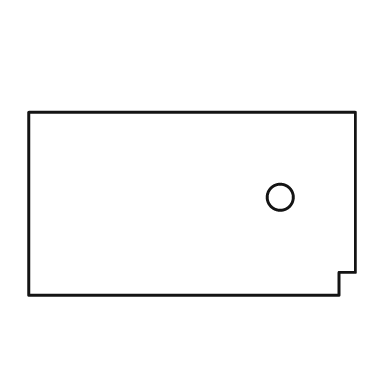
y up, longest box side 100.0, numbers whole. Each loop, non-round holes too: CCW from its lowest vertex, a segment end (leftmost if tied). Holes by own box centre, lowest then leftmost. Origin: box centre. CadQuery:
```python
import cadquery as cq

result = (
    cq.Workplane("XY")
    .moveTo(-50.0, -28.0)
    .lineTo(45.0, -28.0)
    .lineTo(45.0, -21.0)
    .lineTo(50.0, -21.0)
    .lineTo(50.0, 28.0)
    .lineTo(-50.0, 28.0)
    .close()
    .moveTo(27.0, 2.0)
    .circle(4.0)
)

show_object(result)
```